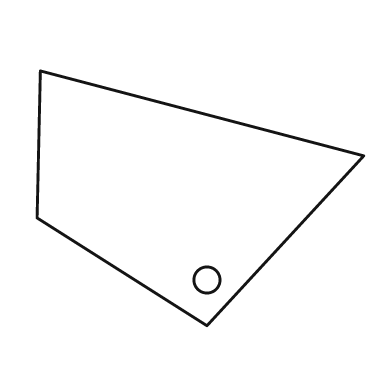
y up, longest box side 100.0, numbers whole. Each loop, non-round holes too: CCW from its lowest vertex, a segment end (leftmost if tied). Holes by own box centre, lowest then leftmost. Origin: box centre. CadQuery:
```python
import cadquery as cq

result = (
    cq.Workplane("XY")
    .moveTo(2.0, -39.0)
    .lineTo(50.0, 13.0)
    .lineTo(-49.0, 39.0)
    .lineTo(-50.0, -6.0)
    .close()
    .moveTo(2.0, -25.0)
    .circle(4.0)
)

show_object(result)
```